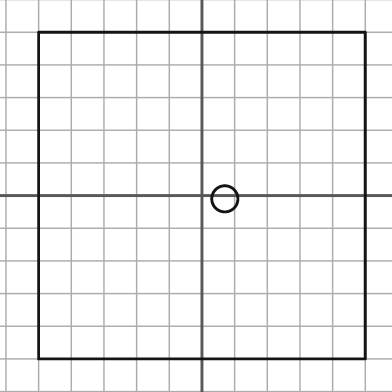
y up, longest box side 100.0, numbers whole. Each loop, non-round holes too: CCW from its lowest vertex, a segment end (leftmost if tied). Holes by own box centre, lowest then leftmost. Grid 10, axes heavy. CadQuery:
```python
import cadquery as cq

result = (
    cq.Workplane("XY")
    .moveTo(-50.0, -50.0)
    .lineTo(50.0, -50.0)
    .lineTo(50.0, 50.0)
    .lineTo(-50.0, 50.0)
    .close()
    .moveTo(7.0, -1.0)
    .circle(4.0)
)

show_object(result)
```